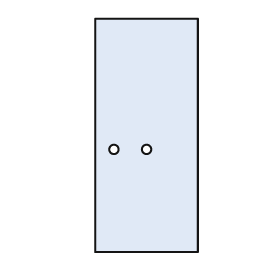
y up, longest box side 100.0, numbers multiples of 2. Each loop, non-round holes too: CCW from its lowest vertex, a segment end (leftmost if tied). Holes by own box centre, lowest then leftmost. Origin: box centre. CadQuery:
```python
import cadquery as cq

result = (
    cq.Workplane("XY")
    .moveTo(-22.0, -50.0)
    .lineTo(22.0, -50.0)
    .lineTo(22.0, 50.0)
    .lineTo(-22.0, 50.0)
    .close()
    .moveTo(-14.0, -6.0)
    .circle(2.0)
    .moveTo(0.0, -6.0)
    .circle(2.0)
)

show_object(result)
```